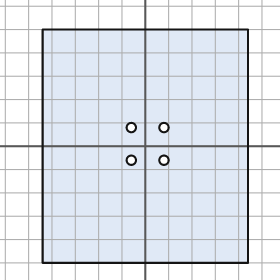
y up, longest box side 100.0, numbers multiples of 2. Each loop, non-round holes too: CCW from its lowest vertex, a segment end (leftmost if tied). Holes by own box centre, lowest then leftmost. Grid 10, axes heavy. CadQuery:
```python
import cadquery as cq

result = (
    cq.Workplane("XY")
    .moveTo(-44.0, -50.0)
    .lineTo(44.0, -50.0)
    .lineTo(44.0, 50.0)
    .lineTo(-44.0, 50.0)
    .close()
    .moveTo(-6.0, -6.0)
    .circle(2.0)
    .moveTo(8.0, -6.0)
    .circle(2.0)
    .moveTo(-6.0, 8.0)
    .circle(2.0)
    .moveTo(8.0, 8.0)
    .circle(2.0)
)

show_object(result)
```